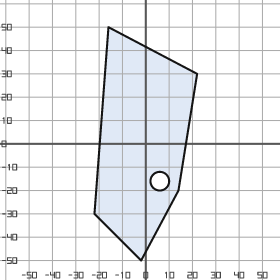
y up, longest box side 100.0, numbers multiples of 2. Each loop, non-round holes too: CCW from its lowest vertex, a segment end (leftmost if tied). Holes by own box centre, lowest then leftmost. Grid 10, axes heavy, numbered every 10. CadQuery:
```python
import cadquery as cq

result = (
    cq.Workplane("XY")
    .moveTo(-2.0, -50.0)
    .lineTo(14.0, -20.0)
    .lineTo(22.0, 30.0)
    .lineTo(-16.0, 50.0)
    .lineTo(-22.0, -30.0)
    .close()
    .moveTo(6.0, -16.0)
    .circle(4.0)
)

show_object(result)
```